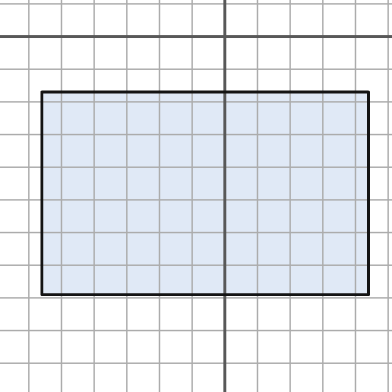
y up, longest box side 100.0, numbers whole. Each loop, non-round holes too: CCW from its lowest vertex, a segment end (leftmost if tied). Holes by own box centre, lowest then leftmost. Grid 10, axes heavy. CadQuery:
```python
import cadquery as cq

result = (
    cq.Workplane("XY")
    .moveTo(-56.0, -79.0)
    .lineTo(44.0, -79.0)
    .lineTo(44.0, -17.0)
    .lineTo(-56.0, -17.0)
    .close()
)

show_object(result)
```